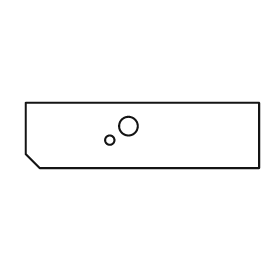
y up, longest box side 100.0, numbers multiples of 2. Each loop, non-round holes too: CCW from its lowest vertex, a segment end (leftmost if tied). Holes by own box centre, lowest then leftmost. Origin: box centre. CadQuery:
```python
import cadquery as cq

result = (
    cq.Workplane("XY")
    .moveTo(-44.0, -14.0)
    .lineTo(50.0, -14.0)
    .lineTo(50.0, 14.0)
    .lineTo(-50.0, 14.0)
    .lineTo(-50.0, -8.0)
    .close()
    .moveTo(-14.0, -2.0)
    .circle(2.0)
    .moveTo(-6.0, 4.0)
    .circle(4.0)
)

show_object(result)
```